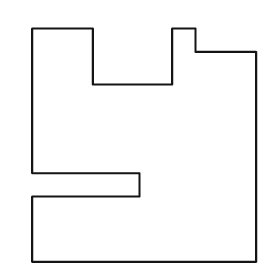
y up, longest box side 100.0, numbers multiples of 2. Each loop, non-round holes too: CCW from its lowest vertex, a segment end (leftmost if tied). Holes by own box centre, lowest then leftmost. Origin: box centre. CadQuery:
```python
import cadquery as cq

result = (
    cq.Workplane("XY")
    .moveTo(-48.0, -50.0)
    .lineTo(48.0, -50.0)
    .lineTo(48.0, 40.0)
    .lineTo(22.0, 40.0)
    .lineTo(22.0, 50.0)
    .lineTo(12.0, 50.0)
    .lineTo(12.0, 26.0)
    .lineTo(-22.0, 26.0)
    .lineTo(-22.0, 50.0)
    .lineTo(-48.0, 50.0)
    .lineTo(-48.0, -12.0)
    .lineTo(-2.0, -12.0)
    .lineTo(-2.0, -22.0)
    .lineTo(-48.0, -22.0)
    .close()
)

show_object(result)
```